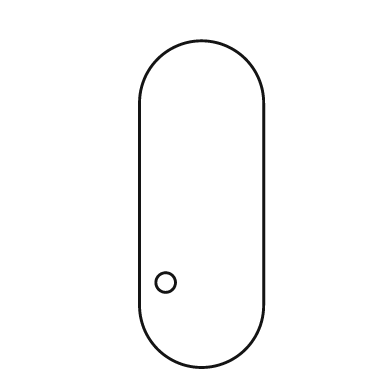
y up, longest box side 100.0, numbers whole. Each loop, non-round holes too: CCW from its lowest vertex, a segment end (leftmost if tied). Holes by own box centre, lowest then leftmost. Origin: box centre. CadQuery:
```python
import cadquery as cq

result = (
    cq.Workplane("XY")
    .moveTo(-19.0, -31.0)
    .threePointArc((0.0, -50.0), (19.0, -31.0))
    .lineTo(19.0, 31.0)
    .threePointArc((0.0, 50.0), (-19.0, 31.0))
    .close()
    .moveTo(-11.0, -24.0)
    .circle(3.0)
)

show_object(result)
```